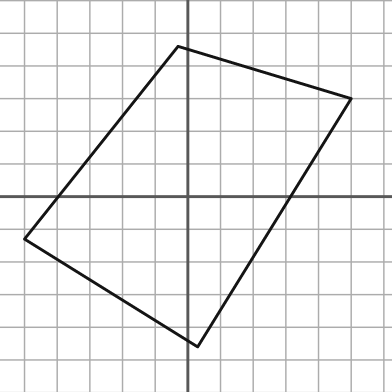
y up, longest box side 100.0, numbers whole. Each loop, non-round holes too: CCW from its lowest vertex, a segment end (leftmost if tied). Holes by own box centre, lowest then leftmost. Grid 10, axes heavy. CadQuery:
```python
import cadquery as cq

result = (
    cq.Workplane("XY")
    .moveTo(3.0, -46.0)
    .lineTo(50.0, 30.0)
    .lineTo(-3.0, 46.0)
    .lineTo(-50.0, -13.0)
    .close()
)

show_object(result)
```